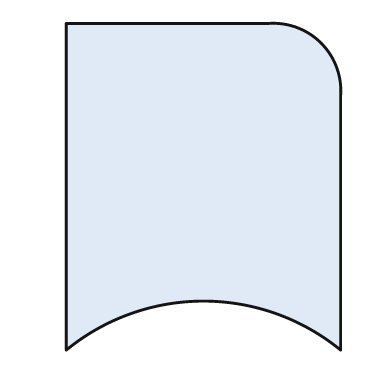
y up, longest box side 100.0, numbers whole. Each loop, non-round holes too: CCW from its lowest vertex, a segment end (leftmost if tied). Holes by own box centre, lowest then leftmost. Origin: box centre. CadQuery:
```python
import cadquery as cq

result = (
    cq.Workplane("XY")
    .moveTo(-42.0, -50.0)
    .threePointArc((0.0, -35.0), (42.0, -50.0))
    .lineTo(42.0, 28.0)
    .threePointArc((36.0, 44.0), (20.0, 50.0))
    .lineTo(-42.0, 50.0)
    .close()
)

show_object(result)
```